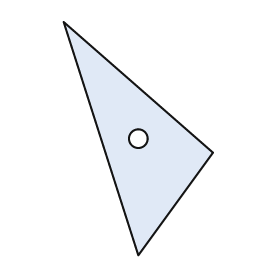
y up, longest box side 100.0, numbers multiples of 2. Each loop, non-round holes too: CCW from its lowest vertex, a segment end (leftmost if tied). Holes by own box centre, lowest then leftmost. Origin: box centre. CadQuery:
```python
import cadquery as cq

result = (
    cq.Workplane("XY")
    .moveTo(0.0, -50.0)
    .lineTo(32.0, -6.0)
    .lineTo(-32.0, 50.0)
    .close()
    .moveTo(0.0, 0.0)
    .circle(4.0)
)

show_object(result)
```